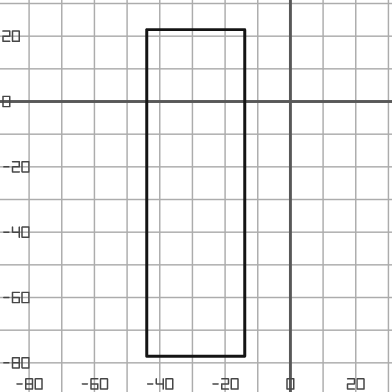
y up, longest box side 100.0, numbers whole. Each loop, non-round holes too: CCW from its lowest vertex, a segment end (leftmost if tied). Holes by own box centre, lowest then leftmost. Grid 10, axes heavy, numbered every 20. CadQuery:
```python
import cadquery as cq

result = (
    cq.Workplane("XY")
    .moveTo(-44.0, -78.0)
    .lineTo(-14.0, -78.0)
    .lineTo(-14.0, 22.0)
    .lineTo(-44.0, 22.0)
    .close()
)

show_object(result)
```